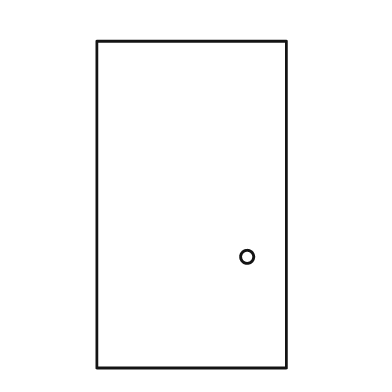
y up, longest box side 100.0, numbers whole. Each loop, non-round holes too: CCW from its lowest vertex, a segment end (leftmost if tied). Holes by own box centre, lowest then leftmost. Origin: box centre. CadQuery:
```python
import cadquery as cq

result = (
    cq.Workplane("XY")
    .moveTo(-29.0, -50.0)
    .lineTo(29.0, -50.0)
    .lineTo(29.0, 50.0)
    .lineTo(-29.0, 50.0)
    .close()
    .moveTo(17.0, -16.0)
    .circle(2.0)
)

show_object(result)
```